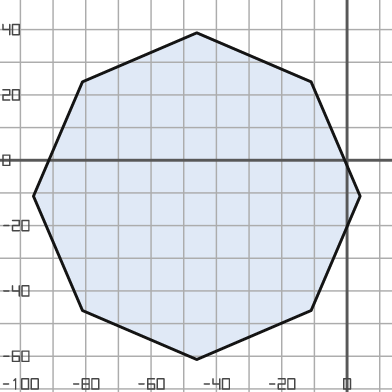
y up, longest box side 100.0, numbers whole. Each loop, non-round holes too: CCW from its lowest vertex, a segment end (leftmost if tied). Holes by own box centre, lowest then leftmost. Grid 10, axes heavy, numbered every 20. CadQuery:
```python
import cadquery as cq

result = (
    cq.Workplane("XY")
    .moveTo(-46.0, -61.0)
    .lineTo(-11.0, -46.0)
    .lineTo(4.0, -11.0)
    .lineTo(-11.0, 24.0)
    .lineTo(-46.0, 39.0)
    .lineTo(-81.0, 24.0)
    .lineTo(-96.0, -11.0)
    .lineTo(-81.0, -46.0)
    .close()
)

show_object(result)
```